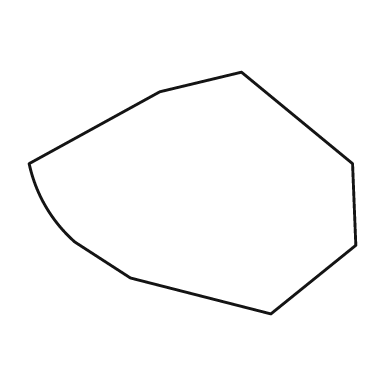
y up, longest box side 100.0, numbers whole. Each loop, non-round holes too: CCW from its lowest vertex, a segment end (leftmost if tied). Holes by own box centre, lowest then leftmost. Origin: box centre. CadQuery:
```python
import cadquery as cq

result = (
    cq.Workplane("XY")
    .moveTo(24.0, -37.0)
    .lineTo(50.0, -16.0)
    .lineTo(49.0, 9.0)
    .lineTo(15.0, 37.0)
    .lineTo(-10.0, 31.0)
    .lineTo(-50.0, 9.0)
    .threePointArc((-45.0, -4.0), (-36.0, -15.0))
    .lineTo(-19.0, -26.0)
    .close()
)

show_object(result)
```